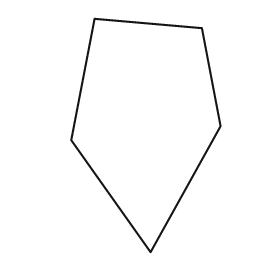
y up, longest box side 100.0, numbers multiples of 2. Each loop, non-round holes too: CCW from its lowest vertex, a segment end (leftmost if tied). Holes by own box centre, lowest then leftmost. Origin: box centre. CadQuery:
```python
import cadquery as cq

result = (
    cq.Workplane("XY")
    .moveTo(2.0, -50.0)
    .lineTo(32.0, 4.0)
    .lineTo(24.0, 46.0)
    .lineTo(-22.0, 50.0)
    .lineTo(-32.0, -2.0)
    .close()
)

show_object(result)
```